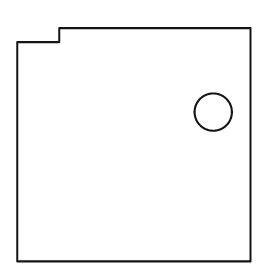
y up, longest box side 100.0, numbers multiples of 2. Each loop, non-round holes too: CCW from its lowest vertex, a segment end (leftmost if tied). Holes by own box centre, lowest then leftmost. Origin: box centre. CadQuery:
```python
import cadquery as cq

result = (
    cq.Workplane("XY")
    .moveTo(-50.0, -50.0)
    .lineTo(50.0, -50.0)
    .lineTo(50.0, 50.0)
    .lineTo(-32.0, 50.0)
    .lineTo(-32.0, 44.0)
    .lineTo(-50.0, 44.0)
    .close()
    .moveTo(34.0, 14.0)
    .circle(8.0)
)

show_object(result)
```